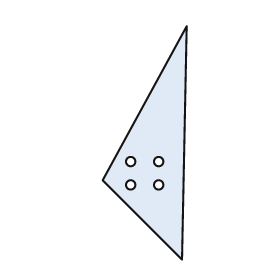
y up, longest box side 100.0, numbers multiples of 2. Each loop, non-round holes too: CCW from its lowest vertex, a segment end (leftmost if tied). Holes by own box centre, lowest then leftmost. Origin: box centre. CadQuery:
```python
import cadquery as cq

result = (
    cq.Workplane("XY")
    .moveTo(16.0, -50.0)
    .lineTo(18.0, 50.0)
    .lineTo(-18.0, -16.0)
    .close()
    .moveTo(-6.0, -18.0)
    .circle(2.0)
    .moveTo(6.0, -18.0)
    .circle(2.0)
    .moveTo(-6.0, -8.0)
    .circle(2.0)
    .moveTo(6.0, -8.0)
    .circle(2.0)
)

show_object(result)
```